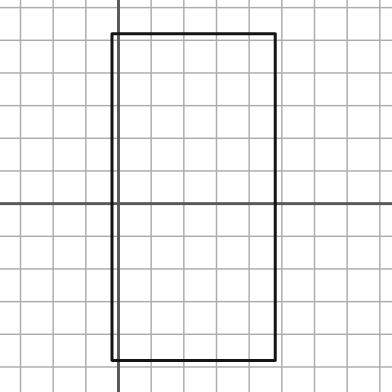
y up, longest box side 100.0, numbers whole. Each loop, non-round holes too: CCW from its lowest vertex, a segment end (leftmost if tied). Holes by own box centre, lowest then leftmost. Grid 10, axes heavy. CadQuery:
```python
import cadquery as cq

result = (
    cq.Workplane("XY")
    .moveTo(-2.0, -48.0)
    .lineTo(48.0, -48.0)
    .lineTo(48.0, 52.0)
    .lineTo(-2.0, 52.0)
    .close()
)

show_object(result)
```